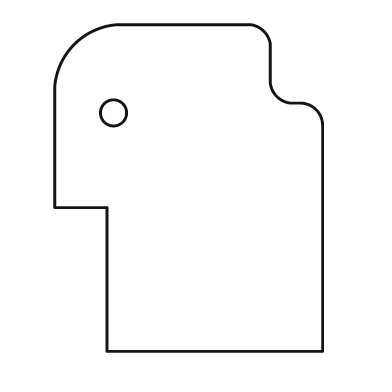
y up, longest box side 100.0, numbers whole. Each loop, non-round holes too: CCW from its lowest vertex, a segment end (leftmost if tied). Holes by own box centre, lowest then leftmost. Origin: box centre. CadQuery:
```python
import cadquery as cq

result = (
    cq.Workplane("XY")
    .moveTo(-25.0, -50.0)
    .lineTo(41.0, -50.0)
    .lineTo(41.0, 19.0)
    .threePointArc((39.0, 24.0), (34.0, 26.0))
    .lineTo(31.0, 26.0)
    .threePointArc((27.0, 28.0), (25.0, 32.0))
    .lineTo(25.0, 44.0)
    .threePointArc((23.0, 48.0), (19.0, 50.0))
    .lineTo(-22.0, 50.0)
    .threePointArc((-35.0, 44.0), (-41.0, 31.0))
    .lineTo(-41.0, -6.0)
    .lineTo(-25.0, -6.0)
    .close()
    .moveTo(-23.0, 23.0)
    .circle(4.0)
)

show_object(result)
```